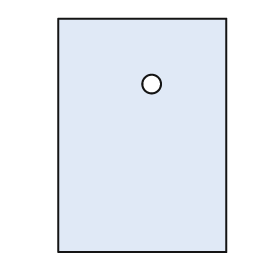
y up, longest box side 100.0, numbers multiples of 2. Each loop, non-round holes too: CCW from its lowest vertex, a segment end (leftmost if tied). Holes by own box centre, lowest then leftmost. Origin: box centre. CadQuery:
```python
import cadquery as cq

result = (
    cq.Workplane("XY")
    .moveTo(-36.0, -50.0)
    .lineTo(36.0, -50.0)
    .lineTo(36.0, 50.0)
    .lineTo(-36.0, 50.0)
    .close()
    .moveTo(4.0, 22.0)
    .circle(4.0)
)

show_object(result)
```